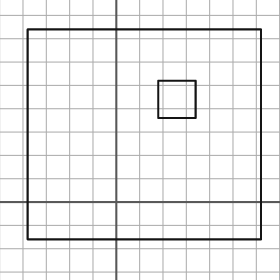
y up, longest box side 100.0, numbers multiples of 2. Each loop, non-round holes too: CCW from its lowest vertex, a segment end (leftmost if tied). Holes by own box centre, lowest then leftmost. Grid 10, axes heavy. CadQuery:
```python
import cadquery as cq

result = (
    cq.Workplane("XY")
    .moveTo(-38.0, -16.0)
    .lineTo(62.0, -16.0)
    .lineTo(62.0, 74.0)
    .lineTo(-38.0, 74.0)
    .close()
    .moveTo(18.0, 36.0)
    .lineTo(34.0, 36.0)
    .lineTo(34.0, 52.0)
    .lineTo(18.0, 52.0)
    .close()
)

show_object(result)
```